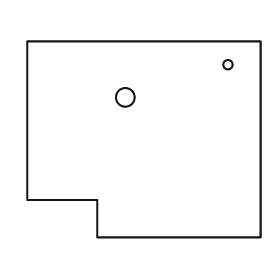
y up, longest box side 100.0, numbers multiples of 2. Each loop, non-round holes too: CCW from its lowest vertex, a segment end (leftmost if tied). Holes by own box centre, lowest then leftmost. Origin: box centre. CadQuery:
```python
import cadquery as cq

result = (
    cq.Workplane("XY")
    .moveTo(-20.0, -42.0)
    .lineTo(50.0, -42.0)
    .lineTo(50.0, 42.0)
    .lineTo(-50.0, 42.0)
    .lineTo(-50.0, -26.0)
    .lineTo(-20.0, -26.0)
    .close()
    .moveTo(-8.0, 18.0)
    .circle(4.0)
    .moveTo(36.0, 32.0)
    .circle(2.0)
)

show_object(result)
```